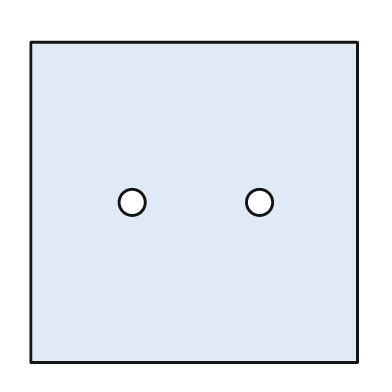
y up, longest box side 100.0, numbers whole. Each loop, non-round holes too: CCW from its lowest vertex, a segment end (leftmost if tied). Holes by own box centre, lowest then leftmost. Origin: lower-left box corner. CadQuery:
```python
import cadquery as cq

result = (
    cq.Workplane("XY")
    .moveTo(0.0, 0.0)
    .lineTo(100.0, 0.0)
    .lineTo(100.0, 98.0)
    .lineTo(0.0, 98.0)
    .close()
    .moveTo(31.0, 49.0)
    .circle(4.0)
    .moveTo(70.0, 49.0)
    .circle(4.0)
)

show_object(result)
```